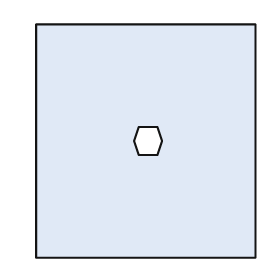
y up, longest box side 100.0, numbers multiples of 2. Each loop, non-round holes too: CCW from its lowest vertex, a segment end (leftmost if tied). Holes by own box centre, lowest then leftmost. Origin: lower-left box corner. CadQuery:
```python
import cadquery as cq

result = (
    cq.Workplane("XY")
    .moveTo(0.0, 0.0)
    .lineTo(94.0, 0.0)
    .lineTo(94.0, 100.0)
    .lineTo(0.0, 100.0)
    .close()
    .moveTo(44.0, 44.0)
    .lineTo(52.0, 44.0)
    .lineTo(54.0, 50.0)
    .lineTo(52.0, 56.0)
    .lineTo(44.0, 56.0)
    .lineTo(42.0, 50.0)
    .close()
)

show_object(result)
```